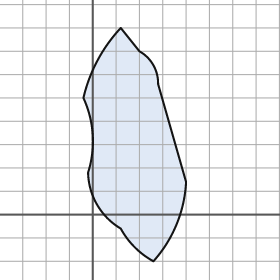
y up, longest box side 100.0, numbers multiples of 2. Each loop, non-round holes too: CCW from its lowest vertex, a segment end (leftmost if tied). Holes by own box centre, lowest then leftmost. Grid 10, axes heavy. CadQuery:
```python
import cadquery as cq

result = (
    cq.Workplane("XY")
    .moveTo(26.0, -20.0)
    .threePointArc((36.0, -4.0), (40.0, 14.0))
    .lineTo(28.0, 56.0)
    .threePointArc((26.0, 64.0), (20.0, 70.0))
    .lineTo(12.0, 80.0)
    .threePointArc((2.0, 66.0), (-4.0, 50.0))
    .threePointArc((0.0, 34.0), (-2.0, 18.0))
    .threePointArc((2.0, 4.0), (12.0, -6.0))
    .threePointArc((18.0, -14.0), (26.0, -20.0))
    .close()
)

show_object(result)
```